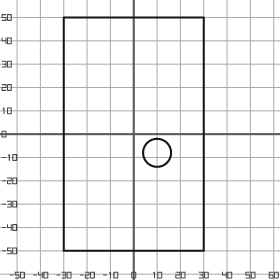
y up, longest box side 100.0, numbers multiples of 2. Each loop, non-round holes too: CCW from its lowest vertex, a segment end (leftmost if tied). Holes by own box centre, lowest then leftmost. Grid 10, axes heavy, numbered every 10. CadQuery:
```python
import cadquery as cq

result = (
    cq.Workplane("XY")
    .moveTo(-30.0, -50.0)
    .lineTo(30.0, -50.0)
    .lineTo(30.0, 50.0)
    .lineTo(-30.0, 50.0)
    .close()
    .moveTo(10.0, -8.0)
    .circle(6.0)
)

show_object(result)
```